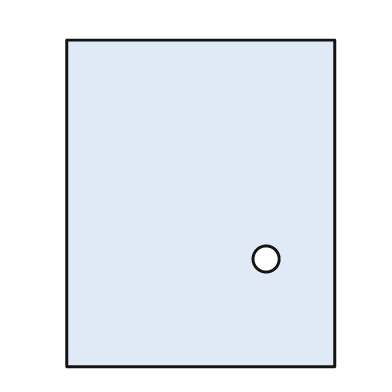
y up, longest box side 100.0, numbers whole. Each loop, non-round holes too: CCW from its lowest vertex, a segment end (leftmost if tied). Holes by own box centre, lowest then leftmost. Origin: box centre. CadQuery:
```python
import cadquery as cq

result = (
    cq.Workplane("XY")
    .moveTo(-41.0, -50.0)
    .lineTo(41.0, -50.0)
    .lineTo(41.0, 50.0)
    .lineTo(-41.0, 50.0)
    .close()
    .moveTo(20.0, -17.0)
    .circle(4.0)
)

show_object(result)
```